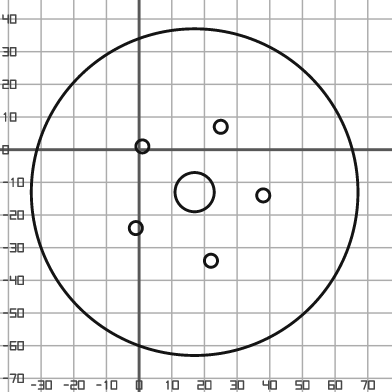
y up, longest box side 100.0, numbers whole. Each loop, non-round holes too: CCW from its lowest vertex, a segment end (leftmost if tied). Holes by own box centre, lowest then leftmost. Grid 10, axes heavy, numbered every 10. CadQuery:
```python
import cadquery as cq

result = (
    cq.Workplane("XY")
    .moveTo(17.0, -13.0)
    .circle(50.0)
    .moveTo(22.0, -34.0)
    .circle(2.0)
    .moveTo(-1.0, -24.0)
    .circle(2.0)
    .moveTo(38.0, -14.0)
    .circle(2.0)
    .moveTo(17.0, -13.0)
    .circle(6.0)
    .moveTo(1.0, 1.0)
    .circle(2.0)
    .moveTo(25.0, 7.0)
    .circle(2.0)
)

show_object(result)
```